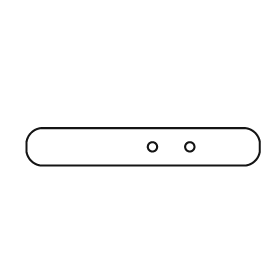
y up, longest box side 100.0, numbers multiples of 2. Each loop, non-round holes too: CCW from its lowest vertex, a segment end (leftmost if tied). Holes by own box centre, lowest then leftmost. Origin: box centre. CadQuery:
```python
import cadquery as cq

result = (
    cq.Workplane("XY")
    .moveTo(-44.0, -8.0)
    .lineTo(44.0, -8.0)
    .threePointArc((48.0, -6.0), (50.0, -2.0))
    .lineTo(50.0, 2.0)
    .threePointArc((48.0, 6.0), (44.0, 8.0))
    .lineTo(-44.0, 8.0)
    .threePointArc((-48.0, 6.0), (-50.0, 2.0))
    .lineTo(-50.0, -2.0)
    .threePointArc((-48.0, -6.0), (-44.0, -8.0))
    .close()
    .moveTo(4.0, 0.0)
    .circle(2.0)
    .moveTo(20.0, 0.0)
    .circle(2.0)
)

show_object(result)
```